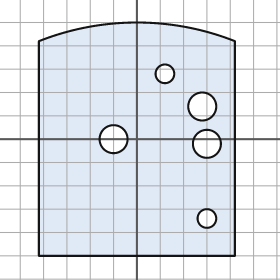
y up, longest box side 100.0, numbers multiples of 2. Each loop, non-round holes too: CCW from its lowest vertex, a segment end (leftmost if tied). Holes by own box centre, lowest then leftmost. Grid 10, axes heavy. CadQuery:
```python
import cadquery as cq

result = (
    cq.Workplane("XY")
    .moveTo(-42.0, -50.0)
    .lineTo(42.0, -50.0)
    .lineTo(42.0, 42.0)
    .threePointArc((0.0, 50.0), (-42.0, 42.0))
    .close()
    .moveTo(30.0, -34.0)
    .circle(4.0)
    .moveTo(30.0, -2.0)
    .circle(6.0)
    .moveTo(-10.0, 0.0)
    .circle(6.0)
    .moveTo(28.0, 14.0)
    .circle(6.0)
    .moveTo(12.0, 28.0)
    .circle(4.0)
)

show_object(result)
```